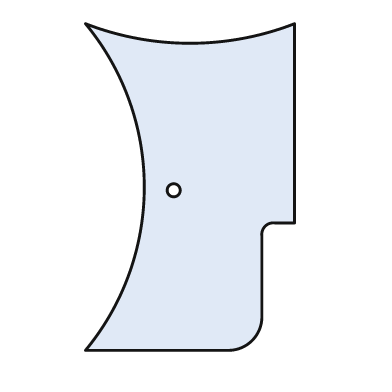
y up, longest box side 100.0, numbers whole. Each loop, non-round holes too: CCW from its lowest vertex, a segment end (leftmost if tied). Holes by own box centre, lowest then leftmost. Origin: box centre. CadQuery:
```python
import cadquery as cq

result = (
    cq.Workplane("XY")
    .moveTo(-32.0, -50.0)
    .lineTo(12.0, -50.0)
    .threePointArc((19.0, -47.0), (22.0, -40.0))
    .lineTo(22.0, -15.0)
    .threePointArc((23.0, -12.0), (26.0, -11.0))
    .lineTo(32.0, -11.0)
    .lineTo(32.0, 50.0)
    .threePointArc((0.0, 44.0), (-32.0, 50.0))
    .threePointArc((-14.0, 0.0), (-32.0, -50.0))
    .close()
    .moveTo(-5.0, -1.0)
    .circle(2.0)
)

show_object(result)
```